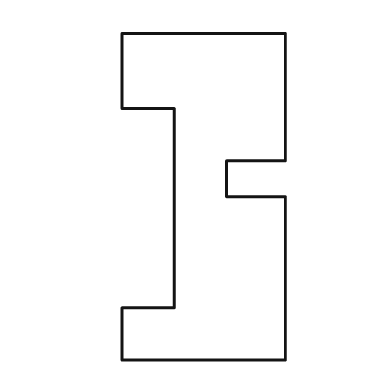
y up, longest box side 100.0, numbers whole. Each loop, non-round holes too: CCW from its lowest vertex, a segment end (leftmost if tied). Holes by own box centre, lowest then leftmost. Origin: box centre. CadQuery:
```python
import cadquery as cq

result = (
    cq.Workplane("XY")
    .moveTo(-25.0, -50.0)
    .lineTo(25.0, -50.0)
    .lineTo(25.0, 0.0)
    .lineTo(7.0, 0.0)
    .lineTo(7.0, 11.0)
    .lineTo(25.0, 11.0)
    .lineTo(25.0, 50.0)
    .lineTo(-25.0, 50.0)
    .lineTo(-25.0, 27.0)
    .lineTo(-9.0, 27.0)
    .lineTo(-9.0, -34.0)
    .lineTo(-25.0, -34.0)
    .close()
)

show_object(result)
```